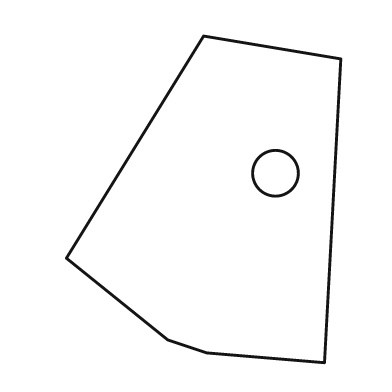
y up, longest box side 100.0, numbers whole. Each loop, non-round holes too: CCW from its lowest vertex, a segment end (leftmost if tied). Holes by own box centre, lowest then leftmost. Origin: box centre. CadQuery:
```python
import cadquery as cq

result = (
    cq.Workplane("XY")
    .moveTo(37.0, -50.0)
    .lineTo(42.0, 43.0)
    .lineTo(0.0, 50.0)
    .lineTo(-42.0, -18.0)
    .lineTo(-11.0, -43.0)
    .lineTo(1.0, -47.0)
    .close()
    .moveTo(22.0, 8.0)
    .circle(7.0)
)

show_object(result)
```